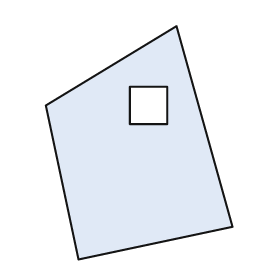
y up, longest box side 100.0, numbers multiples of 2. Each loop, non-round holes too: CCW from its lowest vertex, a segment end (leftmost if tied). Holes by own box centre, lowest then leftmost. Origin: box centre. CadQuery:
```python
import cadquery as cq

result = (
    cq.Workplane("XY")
    .moveTo(-26.0, -50.0)
    .lineTo(40.0, -36.0)
    .lineTo(16.0, 50.0)
    .lineTo(-40.0, 16.0)
    .close()
    .moveTo(-4.0, 8.0)
    .lineTo(12.0, 8.0)
    .lineTo(12.0, 24.0)
    .lineTo(-4.0, 24.0)
    .close()
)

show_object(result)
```